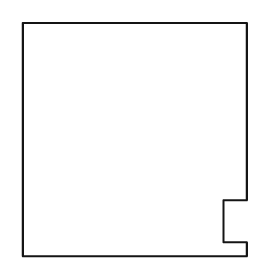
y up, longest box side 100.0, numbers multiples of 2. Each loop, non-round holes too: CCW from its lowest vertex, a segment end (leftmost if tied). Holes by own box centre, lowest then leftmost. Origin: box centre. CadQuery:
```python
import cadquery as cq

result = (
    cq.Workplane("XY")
    .moveTo(-48.0, -50.0)
    .lineTo(48.0, -50.0)
    .lineTo(48.0, -44.0)
    .lineTo(38.0, -44.0)
    .lineTo(38.0, -26.0)
    .lineTo(48.0, -26.0)
    .lineTo(48.0, 50.0)
    .lineTo(-48.0, 50.0)
    .close()
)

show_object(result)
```